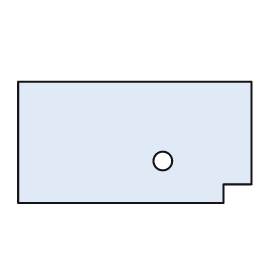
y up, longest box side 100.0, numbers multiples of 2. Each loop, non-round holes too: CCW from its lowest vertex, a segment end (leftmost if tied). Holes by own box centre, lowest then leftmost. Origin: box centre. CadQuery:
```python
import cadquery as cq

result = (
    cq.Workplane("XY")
    .moveTo(-50.0, -26.0)
    .lineTo(38.0, -26.0)
    .lineTo(38.0, -18.0)
    .lineTo(50.0, -18.0)
    .lineTo(50.0, 26.0)
    .lineTo(-50.0, 26.0)
    .close()
    .moveTo(12.0, -8.0)
    .circle(4.0)
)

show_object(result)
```